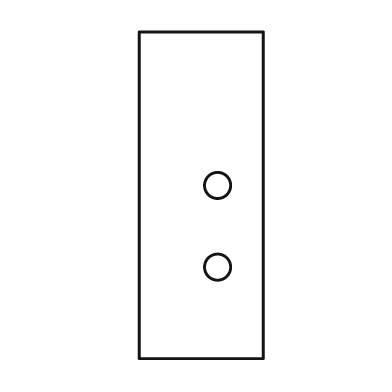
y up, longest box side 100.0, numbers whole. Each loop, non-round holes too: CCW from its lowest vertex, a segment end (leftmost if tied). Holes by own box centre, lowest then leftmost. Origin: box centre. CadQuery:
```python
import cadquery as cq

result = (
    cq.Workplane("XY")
    .moveTo(-19.0, -50.0)
    .lineTo(19.0, -50.0)
    .lineTo(19.0, 50.0)
    .lineTo(-19.0, 50.0)
    .close()
    .moveTo(5.0, -22.0)
    .circle(4.0)
    .moveTo(5.0, 3.0)
    .circle(4.0)
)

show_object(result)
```